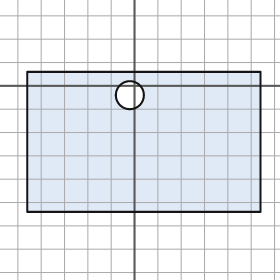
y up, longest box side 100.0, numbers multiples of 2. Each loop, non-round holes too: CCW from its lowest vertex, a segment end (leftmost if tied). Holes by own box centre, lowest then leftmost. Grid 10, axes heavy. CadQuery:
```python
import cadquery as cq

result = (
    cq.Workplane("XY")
    .moveTo(-46.0, -54.0)
    .lineTo(54.0, -54.0)
    .lineTo(54.0, 6.0)
    .lineTo(-46.0, 6.0)
    .close()
    .moveTo(-2.0, -4.0)
    .circle(6.0)
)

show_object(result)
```